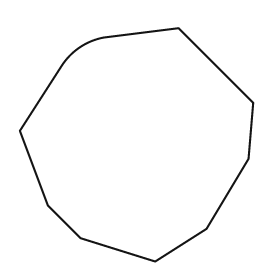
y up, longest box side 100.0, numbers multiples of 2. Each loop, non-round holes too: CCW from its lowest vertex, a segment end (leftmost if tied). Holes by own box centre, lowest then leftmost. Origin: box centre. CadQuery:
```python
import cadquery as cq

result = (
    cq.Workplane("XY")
    .moveTo(8.0, -50.0)
    .lineTo(30.0, -36.0)
    .lineTo(48.0, -6.0)
    .lineTo(50.0, 18.0)
    .lineTo(18.0, 50.0)
    .lineTo(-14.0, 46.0)
    .threePointArc((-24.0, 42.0), (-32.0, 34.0))
    .lineTo(-50.0, 6.0)
    .lineTo(-38.0, -26.0)
    .lineTo(-24.0, -40.0)
    .close()
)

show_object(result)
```